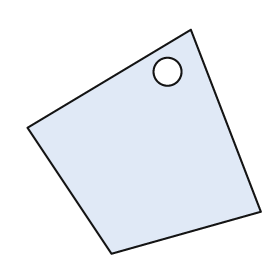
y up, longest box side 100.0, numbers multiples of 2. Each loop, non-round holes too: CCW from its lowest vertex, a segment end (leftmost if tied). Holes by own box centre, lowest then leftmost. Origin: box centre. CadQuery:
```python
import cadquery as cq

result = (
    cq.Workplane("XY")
    .moveTo(-14.0, -48.0)
    .lineTo(50.0, -30.0)
    .lineTo(20.0, 48.0)
    .lineTo(-50.0, 6.0)
    .close()
    .moveTo(10.0, 30.0)
    .circle(6.0)
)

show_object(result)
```